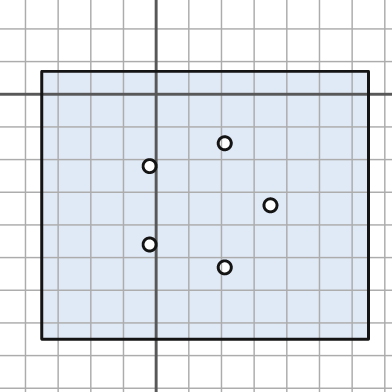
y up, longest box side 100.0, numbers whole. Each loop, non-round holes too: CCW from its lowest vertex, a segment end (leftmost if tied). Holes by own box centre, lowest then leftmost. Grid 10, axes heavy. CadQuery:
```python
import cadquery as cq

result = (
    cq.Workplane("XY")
    .moveTo(-35.0, -75.0)
    .lineTo(65.0, -75.0)
    .lineTo(65.0, 7.0)
    .lineTo(-35.0, 7.0)
    .close()
    .moveTo(21.0, -53.0)
    .circle(2.0)
    .moveTo(-2.0, -46.0)
    .circle(2.0)
    .moveTo(35.0, -34.0)
    .circle(2.0)
    .moveTo(-2.0, -22.0)
    .circle(2.0)
    .moveTo(21.0, -15.0)
    .circle(2.0)
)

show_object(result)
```